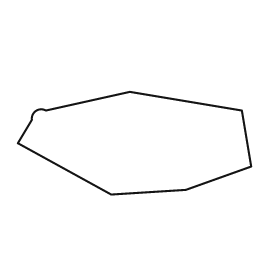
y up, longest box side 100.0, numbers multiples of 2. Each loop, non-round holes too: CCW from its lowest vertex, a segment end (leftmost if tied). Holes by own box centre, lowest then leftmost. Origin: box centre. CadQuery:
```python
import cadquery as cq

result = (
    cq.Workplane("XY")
    .moveTo(-10.0, -22.0)
    .lineTo(22.0, -20.0)
    .lineTo(50.0, -10.0)
    .lineTo(46.0, 14.0)
    .lineTo(-2.0, 22.0)
    .lineTo(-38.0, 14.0)
    .threePointArc((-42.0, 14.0), (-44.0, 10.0))
    .lineTo(-50.0, 0.0)
    .close()
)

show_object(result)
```